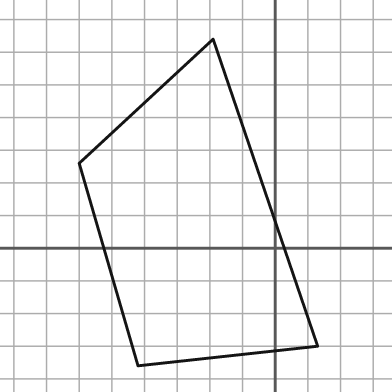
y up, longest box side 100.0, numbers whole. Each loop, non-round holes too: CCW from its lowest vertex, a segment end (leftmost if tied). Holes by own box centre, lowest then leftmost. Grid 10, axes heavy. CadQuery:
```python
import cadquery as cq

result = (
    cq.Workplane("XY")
    .moveTo(-42.0, -36.0)
    .lineTo(13.0, -30.0)
    .lineTo(-19.0, 64.0)
    .lineTo(-60.0, 26.0)
    .close()
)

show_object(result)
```